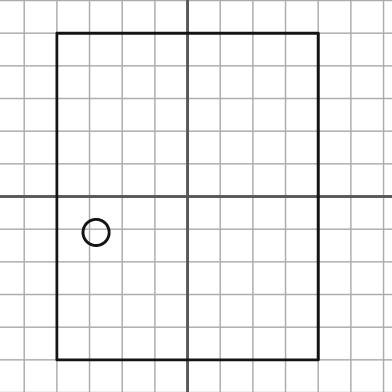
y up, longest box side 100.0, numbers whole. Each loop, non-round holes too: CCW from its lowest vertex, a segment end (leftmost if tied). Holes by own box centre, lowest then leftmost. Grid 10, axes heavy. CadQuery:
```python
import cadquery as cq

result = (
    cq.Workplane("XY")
    .moveTo(-40.0, -50.0)
    .lineTo(40.0, -50.0)
    .lineTo(40.0, 50.0)
    .lineTo(-40.0, 50.0)
    .close()
    .moveTo(-28.0, -11.0)
    .circle(4.0)
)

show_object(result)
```